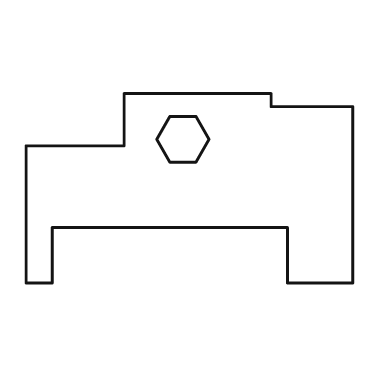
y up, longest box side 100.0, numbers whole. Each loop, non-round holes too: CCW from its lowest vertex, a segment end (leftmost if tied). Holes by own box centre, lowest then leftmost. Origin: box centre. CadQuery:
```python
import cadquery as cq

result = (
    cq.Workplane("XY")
    .moveTo(-50.0, -29.0)
    .lineTo(-42.0, -29.0)
    .lineTo(-42.0, -12.0)
    .lineTo(30.0, -12.0)
    .lineTo(30.0, -29.0)
    .lineTo(50.0, -29.0)
    .lineTo(50.0, 25.0)
    .lineTo(25.0, 25.0)
    .lineTo(25.0, 29.0)
    .lineTo(-20.0, 29.0)
    .lineTo(-20.0, 13.0)
    .lineTo(-50.0, 13.0)
    .close()
    .moveTo(-6.0, 8.0)
    .lineTo(2.0, 8.0)
    .lineTo(6.0, 15.0)
    .lineTo(2.0, 22.0)
    .lineTo(-6.0, 22.0)
    .lineTo(-10.0, 15.0)
    .close()
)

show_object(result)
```